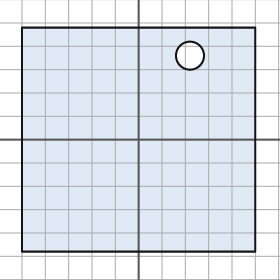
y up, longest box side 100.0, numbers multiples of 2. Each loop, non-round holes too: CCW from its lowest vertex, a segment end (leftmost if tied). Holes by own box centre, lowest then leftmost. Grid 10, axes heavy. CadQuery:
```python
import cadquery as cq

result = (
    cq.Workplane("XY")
    .moveTo(-50.0, -48.0)
    .lineTo(50.0, -48.0)
    .lineTo(50.0, 48.0)
    .lineTo(-50.0, 48.0)
    .close()
    .moveTo(22.0, 36.0)
    .circle(6.0)
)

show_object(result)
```